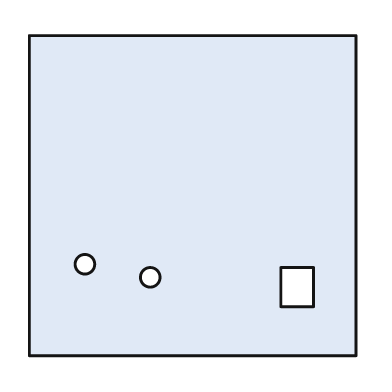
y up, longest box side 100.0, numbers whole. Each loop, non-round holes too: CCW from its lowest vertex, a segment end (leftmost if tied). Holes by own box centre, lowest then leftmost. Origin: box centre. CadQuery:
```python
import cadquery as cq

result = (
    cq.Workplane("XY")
    .moveTo(-50.0, -49.0)
    .lineTo(50.0, -49.0)
    .lineTo(50.0, 49.0)
    .lineTo(-50.0, 49.0)
    .close()
    .moveTo(27.0, -34.0)
    .lineTo(37.0, -34.0)
    .lineTo(37.0, -22.0)
    .lineTo(27.0, -22.0)
    .close()
    .moveTo(-13.0, -25.0)
    .circle(3.0)
    .moveTo(-33.0, -21.0)
    .circle(3.0)
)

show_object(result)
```